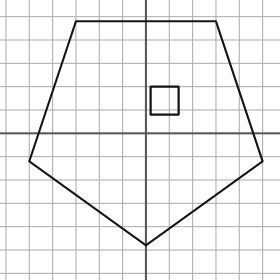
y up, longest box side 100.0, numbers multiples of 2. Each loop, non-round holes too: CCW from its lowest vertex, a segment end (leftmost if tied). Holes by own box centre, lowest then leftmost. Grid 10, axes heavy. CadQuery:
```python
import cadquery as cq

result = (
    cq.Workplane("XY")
    .moveTo(0.0, -48.0)
    .lineTo(50.0, -12.0)
    .lineTo(30.0, 48.0)
    .lineTo(-30.0, 48.0)
    .lineTo(-50.0, -12.0)
    .close()
    .moveTo(2.0, 8.0)
    .lineTo(14.0, 8.0)
    .lineTo(14.0, 20.0)
    .lineTo(2.0, 20.0)
    .close()
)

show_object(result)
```